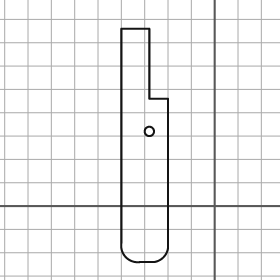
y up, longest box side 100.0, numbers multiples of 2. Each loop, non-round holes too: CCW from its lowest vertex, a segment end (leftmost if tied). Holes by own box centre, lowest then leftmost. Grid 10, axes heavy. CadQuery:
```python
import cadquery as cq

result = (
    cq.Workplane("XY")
    .moveTo(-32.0, -24.0)
    .lineTo(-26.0, -24.0)
    .threePointArc((-22.0, -22.0), (-20.0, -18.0))
    .lineTo(-20.0, 46.0)
    .lineTo(-28.0, 46.0)
    .lineTo(-28.0, 76.0)
    .lineTo(-40.0, 76.0)
    .lineTo(-40.0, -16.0)
    .threePointArc((-38.0, -22.0), (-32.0, -24.0))
    .close()
    .moveTo(-28.0, 32.0)
    .circle(2.0)
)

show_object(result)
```